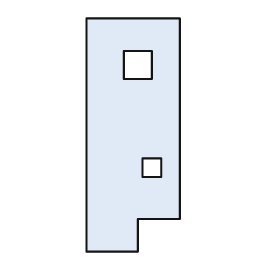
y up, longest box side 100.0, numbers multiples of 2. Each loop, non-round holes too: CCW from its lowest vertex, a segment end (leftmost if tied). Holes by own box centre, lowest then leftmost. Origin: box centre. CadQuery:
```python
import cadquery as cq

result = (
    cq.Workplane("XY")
    .moveTo(-20.0, -50.0)
    .lineTo(2.0, -50.0)
    .lineTo(2.0, -36.0)
    .lineTo(20.0, -36.0)
    .lineTo(20.0, 50.0)
    .lineTo(-20.0, 50.0)
    .close()
    .moveTo(4.0, -18.0)
    .lineTo(12.0, -18.0)
    .lineTo(12.0, -10.0)
    .lineTo(4.0, -10.0)
    .close()
    .moveTo(-4.0, 24.0)
    .lineTo(8.0, 24.0)
    .lineTo(8.0, 36.0)
    .lineTo(-4.0, 36.0)
    .close()
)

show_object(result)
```